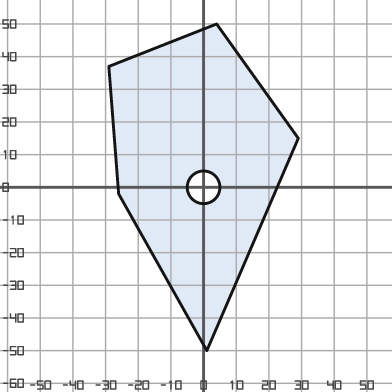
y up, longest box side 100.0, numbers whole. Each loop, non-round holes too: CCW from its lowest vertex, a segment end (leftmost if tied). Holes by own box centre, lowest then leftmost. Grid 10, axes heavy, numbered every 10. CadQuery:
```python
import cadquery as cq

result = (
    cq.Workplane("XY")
    .moveTo(1.0, -50.0)
    .lineTo(29.0, 15.0)
    .lineTo(4.0, 50.0)
    .lineTo(-29.0, 37.0)
    .lineTo(-26.0, -2.0)
    .close()
    .moveTo(0.0, 0.0)
    .circle(5.0)
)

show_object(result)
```